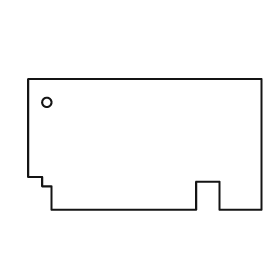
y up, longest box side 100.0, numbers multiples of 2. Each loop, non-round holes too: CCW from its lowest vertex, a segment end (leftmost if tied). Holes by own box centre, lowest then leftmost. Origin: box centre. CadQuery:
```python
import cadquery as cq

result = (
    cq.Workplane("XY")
    .moveTo(-40.0, -28.0)
    .lineTo(22.0, -28.0)
    .lineTo(22.0, -16.0)
    .lineTo(32.0, -16.0)
    .lineTo(32.0, -28.0)
    .lineTo(50.0, -28.0)
    .lineTo(50.0, 28.0)
    .lineTo(-50.0, 28.0)
    .lineTo(-50.0, -14.0)
    .lineTo(-44.0, -14.0)
    .lineTo(-44.0, -18.0)
    .lineTo(-40.0, -18.0)
    .close()
    .moveTo(-42.0, 18.0)
    .circle(2.0)
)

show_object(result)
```